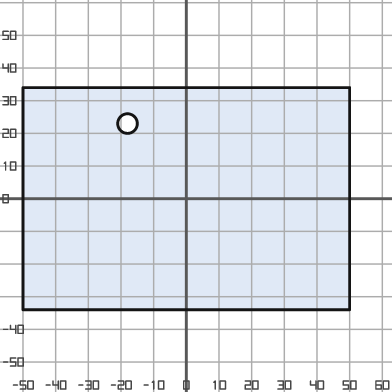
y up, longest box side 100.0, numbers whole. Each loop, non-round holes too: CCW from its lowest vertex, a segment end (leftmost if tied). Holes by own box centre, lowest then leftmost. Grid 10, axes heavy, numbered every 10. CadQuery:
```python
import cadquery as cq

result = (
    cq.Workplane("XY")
    .moveTo(-50.0, -34.0)
    .lineTo(50.0, -34.0)
    .lineTo(50.0, 34.0)
    .lineTo(-50.0, 34.0)
    .close()
    .moveTo(-18.0, 23.0)
    .circle(3.0)
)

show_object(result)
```